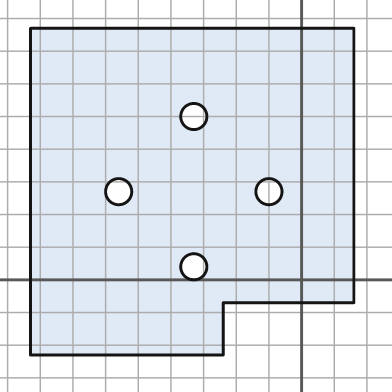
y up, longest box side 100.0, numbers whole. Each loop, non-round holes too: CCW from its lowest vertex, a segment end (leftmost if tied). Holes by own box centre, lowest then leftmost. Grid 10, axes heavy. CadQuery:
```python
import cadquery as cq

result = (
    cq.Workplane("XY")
    .moveTo(-83.0, -23.0)
    .lineTo(-24.0, -23.0)
    .lineTo(-24.0, -7.0)
    .lineTo(16.0, -7.0)
    .lineTo(16.0, 77.0)
    .lineTo(-83.0, 77.0)
    .close()
    .moveTo(-33.0, 4.0)
    .circle(4.0)
    .moveTo(-56.0, 27.0)
    .circle(4.0)
    .moveTo(-10.0, 27.0)
    .circle(4.0)
    .moveTo(-33.0, 50.0)
    .circle(4.0)
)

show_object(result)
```